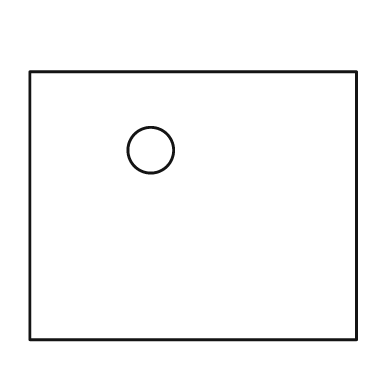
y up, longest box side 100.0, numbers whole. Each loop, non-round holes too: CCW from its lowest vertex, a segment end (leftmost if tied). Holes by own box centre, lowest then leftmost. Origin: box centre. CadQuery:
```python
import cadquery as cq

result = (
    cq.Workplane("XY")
    .moveTo(-50.0, -41.0)
    .lineTo(50.0, -41.0)
    .lineTo(50.0, 41.0)
    .lineTo(-50.0, 41.0)
    .close()
    .moveTo(-13.0, 17.0)
    .circle(7.0)
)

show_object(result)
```